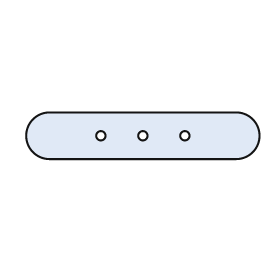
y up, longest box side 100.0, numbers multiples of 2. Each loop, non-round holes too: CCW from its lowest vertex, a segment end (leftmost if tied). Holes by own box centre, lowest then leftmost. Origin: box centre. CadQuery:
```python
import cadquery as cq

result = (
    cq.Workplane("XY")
    .moveTo(-40.0, -10.0)
    .lineTo(40.0, -10.0)
    .threePointArc((50.0, 0.0), (40.0, 10.0))
    .lineTo(-40.0, 10.0)
    .threePointArc((-50.0, 0.0), (-40.0, -10.0))
    .close()
    .moveTo(-18.0, 0.0)
    .circle(2.0)
    .moveTo(0.0, 0.0)
    .circle(2.0)
    .moveTo(18.0, 0.0)
    .circle(2.0)
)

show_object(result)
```